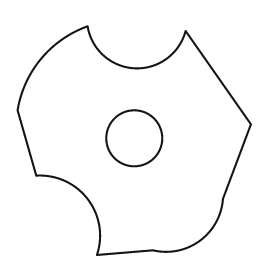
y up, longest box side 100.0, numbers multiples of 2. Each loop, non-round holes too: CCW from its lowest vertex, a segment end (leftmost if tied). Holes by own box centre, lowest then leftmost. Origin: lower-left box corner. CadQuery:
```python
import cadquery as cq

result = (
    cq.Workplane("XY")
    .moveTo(34.0, 0.0)
    .lineTo(58.0, 2.0)
    .threePointArc((78.0, 6.0), (88.0, 24.0))
    .lineTo(100.0, 56.0)
    .lineTo(72.0, 96.0)
    .threePointArc((50.0, 80.0), (30.0, 98.0))
    .threePointArc((10.0, 84.0), (0.0, 62.0))
    .lineTo(8.0, 34.0)
    .threePointArc((30.0, 24.0), (34.0, 0.0))
    .close()
    .moveTo(50.0, 50.0)
    .circle(12.0)
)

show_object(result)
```